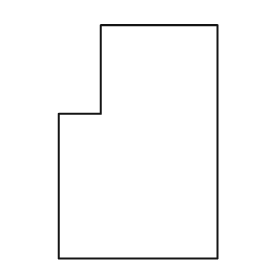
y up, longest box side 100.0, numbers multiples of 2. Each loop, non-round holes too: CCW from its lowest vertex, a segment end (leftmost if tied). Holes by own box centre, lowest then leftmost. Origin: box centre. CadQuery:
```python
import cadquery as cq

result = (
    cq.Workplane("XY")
    .moveTo(-34.0, -50.0)
    .lineTo(34.0, -50.0)
    .lineTo(34.0, 50.0)
    .lineTo(-16.0, 50.0)
    .lineTo(-16.0, 12.0)
    .lineTo(-34.0, 12.0)
    .close()
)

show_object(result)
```